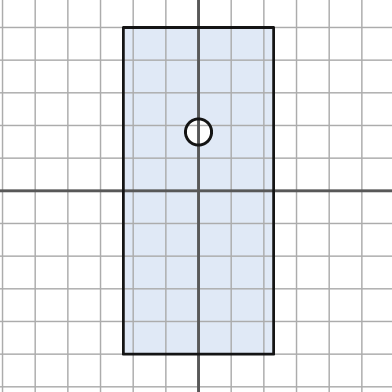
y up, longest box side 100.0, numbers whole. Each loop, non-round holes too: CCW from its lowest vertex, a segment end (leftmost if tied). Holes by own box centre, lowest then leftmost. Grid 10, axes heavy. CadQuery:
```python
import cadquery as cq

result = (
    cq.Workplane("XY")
    .moveTo(-23.0, -50.0)
    .lineTo(23.0, -50.0)
    .lineTo(23.0, 50.0)
    .lineTo(-23.0, 50.0)
    .close()
    .moveTo(0.0, 18.0)
    .circle(4.0)
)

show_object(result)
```